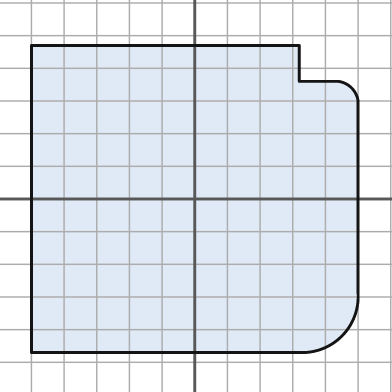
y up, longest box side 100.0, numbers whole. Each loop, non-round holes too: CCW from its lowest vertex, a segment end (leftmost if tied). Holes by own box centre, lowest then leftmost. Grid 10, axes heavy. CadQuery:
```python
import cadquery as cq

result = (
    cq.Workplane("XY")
    .moveTo(-50.0, -47.0)
    .lineTo(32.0, -47.0)
    .threePointArc((45.0, -42.0), (50.0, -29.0))
    .lineTo(50.0, 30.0)
    .threePointArc((48.0, 34.0), (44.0, 36.0))
    .lineTo(32.0, 36.0)
    .lineTo(32.0, 47.0)
    .lineTo(-50.0, 47.0)
    .close()
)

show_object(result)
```